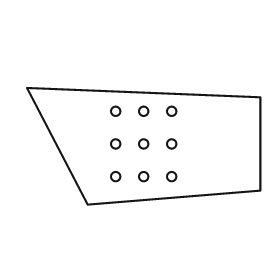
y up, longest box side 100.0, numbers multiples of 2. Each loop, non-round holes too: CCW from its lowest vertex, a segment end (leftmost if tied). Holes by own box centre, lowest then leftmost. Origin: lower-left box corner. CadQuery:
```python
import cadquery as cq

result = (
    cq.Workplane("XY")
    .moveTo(26.0, 0.0)
    .lineTo(100.0, 6.0)
    .lineTo(100.0, 46.0)
    .lineTo(0.0, 50.0)
    .close()
    .moveTo(38.0, 12.0)
    .circle(2.0)
    .moveTo(50.0, 12.0)
    .circle(2.0)
    .moveTo(62.0, 12.0)
    .circle(2.0)
    .moveTo(38.0, 26.0)
    .circle(2.0)
    .moveTo(50.0, 26.0)
    .circle(2.0)
    .moveTo(62.0, 26.0)
    .circle(2.0)
    .moveTo(38.0, 40.0)
    .circle(2.0)
    .moveTo(50.0, 40.0)
    .circle(2.0)
    .moveTo(62.0, 40.0)
    .circle(2.0)
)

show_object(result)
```